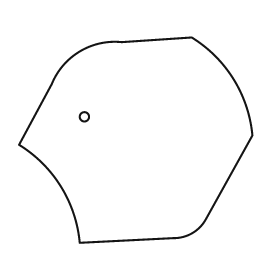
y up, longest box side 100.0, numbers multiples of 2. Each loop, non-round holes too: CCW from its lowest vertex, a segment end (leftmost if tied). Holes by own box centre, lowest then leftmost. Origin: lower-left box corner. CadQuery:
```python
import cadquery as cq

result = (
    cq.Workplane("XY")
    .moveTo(26.0, 0.0)
    .lineTo(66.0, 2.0)
    .threePointArc((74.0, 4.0), (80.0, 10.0))
    .lineTo(100.0, 46.0)
    .threePointArc((92.0, 70.0), (74.0, 88.0))
    .lineTo(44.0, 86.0)
    .threePointArc((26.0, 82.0), (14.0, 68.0))
    .lineTo(0.0, 42.0)
    .threePointArc((18.0, 24.0), (26.0, 0.0))
    .close()
    .moveTo(28.0, 54.0)
    .circle(2.0)
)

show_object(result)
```